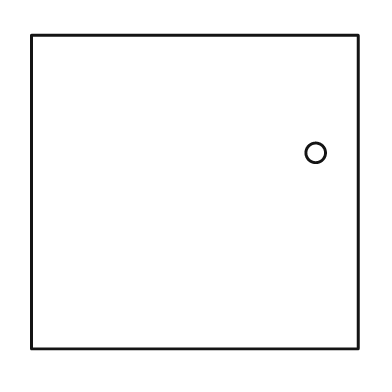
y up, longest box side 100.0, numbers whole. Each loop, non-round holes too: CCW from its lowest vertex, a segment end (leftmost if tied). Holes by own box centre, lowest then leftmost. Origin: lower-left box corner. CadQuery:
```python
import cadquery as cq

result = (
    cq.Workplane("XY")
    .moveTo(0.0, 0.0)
    .lineTo(100.0, 0.0)
    .lineTo(100.0, 96.0)
    .lineTo(0.0, 96.0)
    .close()
    .moveTo(87.0, 60.0)
    .circle(3.0)
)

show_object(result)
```